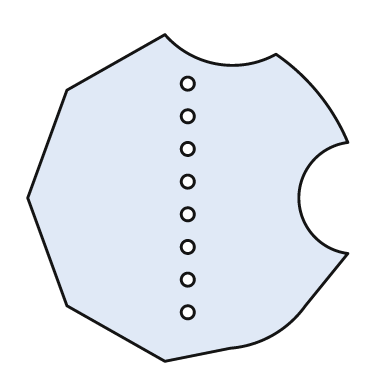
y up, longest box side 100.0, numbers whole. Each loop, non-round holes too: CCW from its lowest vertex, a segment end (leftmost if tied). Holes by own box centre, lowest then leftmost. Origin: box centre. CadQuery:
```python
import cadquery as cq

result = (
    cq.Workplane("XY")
    .moveTo(-7.0, -50.0)
    .lineTo(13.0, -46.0)
    .threePointArc((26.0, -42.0), (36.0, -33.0))
    .lineTo(49.0, -17.0)
    .threePointArc((34.0, 0.0), (49.0, 17.0))
    .threePointArc((40.0, 32.0), (27.0, 44.0))
    .threePointArc((9.0, 41.0), (-7.0, 50.0))
    .lineTo(-37.0, 33.0)
    .lineTo(-49.0, 0.0)
    .lineTo(-37.0, -33.0)
    .close()
    .moveTo(0.0, -35.0)
    .circle(2.0)
    .moveTo(0.0, -25.0)
    .circle(2.0)
    .moveTo(0.0, -15.0)
    .circle(2.0)
    .moveTo(0.0, -5.0)
    .circle(2.0)
    .moveTo(0.0, 5.0)
    .circle(2.0)
    .moveTo(0.0, 15.0)
    .circle(2.0)
    .moveTo(0.0, 25.0)
    .circle(2.0)
    .moveTo(0.0, 35.0)
    .circle(2.0)
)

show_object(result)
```